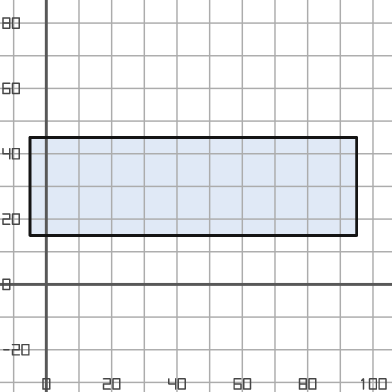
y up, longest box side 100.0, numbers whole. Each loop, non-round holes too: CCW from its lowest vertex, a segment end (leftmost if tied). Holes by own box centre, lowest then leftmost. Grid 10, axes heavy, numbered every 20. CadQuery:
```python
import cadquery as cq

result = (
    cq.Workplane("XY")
    .moveTo(-5.0, 15.0)
    .lineTo(95.0, 15.0)
    .lineTo(95.0, 45.0)
    .lineTo(-5.0, 45.0)
    .close()
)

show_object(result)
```